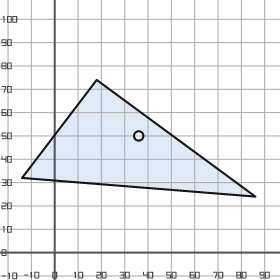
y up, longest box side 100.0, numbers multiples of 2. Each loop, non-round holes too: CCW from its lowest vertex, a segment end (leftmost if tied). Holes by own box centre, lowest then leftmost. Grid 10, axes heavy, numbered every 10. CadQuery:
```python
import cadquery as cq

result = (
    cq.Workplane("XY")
    .moveTo(86.0, 24.0)
    .lineTo(18.0, 74.0)
    .lineTo(-14.0, 32.0)
    .close()
    .moveTo(36.0, 50.0)
    .circle(2.0)
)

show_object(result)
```